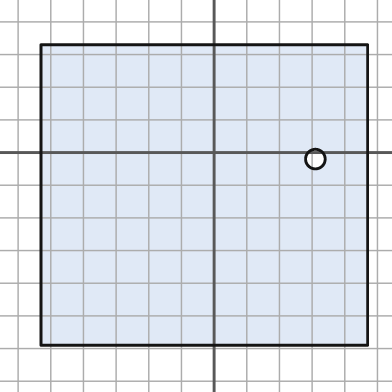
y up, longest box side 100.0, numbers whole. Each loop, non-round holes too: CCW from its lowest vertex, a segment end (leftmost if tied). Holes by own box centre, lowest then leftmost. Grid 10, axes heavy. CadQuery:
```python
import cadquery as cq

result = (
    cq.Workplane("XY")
    .moveTo(-53.0, -59.0)
    .lineTo(47.0, -59.0)
    .lineTo(47.0, 33.0)
    .lineTo(-53.0, 33.0)
    .close()
    .moveTo(31.0, -2.0)
    .circle(3.0)
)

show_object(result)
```